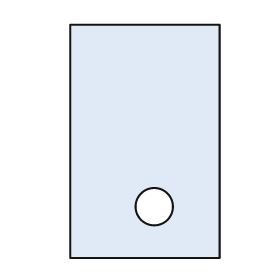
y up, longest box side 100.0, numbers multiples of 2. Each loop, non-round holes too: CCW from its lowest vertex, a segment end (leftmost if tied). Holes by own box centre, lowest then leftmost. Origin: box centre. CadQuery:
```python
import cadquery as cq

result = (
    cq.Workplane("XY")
    .moveTo(-32.0, -50.0)
    .lineTo(32.0, -50.0)
    .lineTo(32.0, 50.0)
    .lineTo(-32.0, 50.0)
    .close()
    .moveTo(4.0, -28.0)
    .circle(8.0)
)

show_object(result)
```